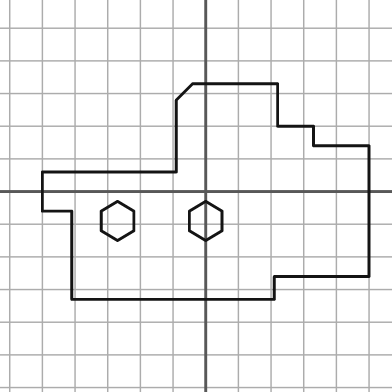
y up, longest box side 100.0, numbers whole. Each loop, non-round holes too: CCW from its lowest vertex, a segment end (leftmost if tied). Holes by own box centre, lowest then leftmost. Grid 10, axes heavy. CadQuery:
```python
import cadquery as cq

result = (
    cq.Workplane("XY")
    .moveTo(-41.0, -33.0)
    .lineTo(21.0, -33.0)
    .lineTo(21.0, -26.0)
    .lineTo(50.0, -26.0)
    .lineTo(50.0, 14.0)
    .lineTo(33.0, 14.0)
    .lineTo(33.0, 20.0)
    .lineTo(22.0, 20.0)
    .lineTo(22.0, 33.0)
    .lineTo(-4.0, 33.0)
    .lineTo(-9.0, 28.0)
    .lineTo(-9.0, 6.0)
    .lineTo(-50.0, 6.0)
    .lineTo(-50.0, -6.0)
    .lineTo(-41.0, -6.0)
    .close()
    .moveTo(-27.0, -15.0)
    .lineTo(-22.0, -12.0)
    .lineTo(-22.0, -6.0)
    .lineTo(-27.0, -3.0)
    .lineTo(-32.0, -6.0)
    .lineTo(-32.0, -12.0)
    .close()
    .moveTo(0.0, -15.0)
    .lineTo(5.0, -12.0)
    .lineTo(5.0, -6.0)
    .lineTo(0.0, -3.0)
    .lineTo(-5.0, -6.0)
    .lineTo(-5.0, -12.0)
    .close()
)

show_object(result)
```